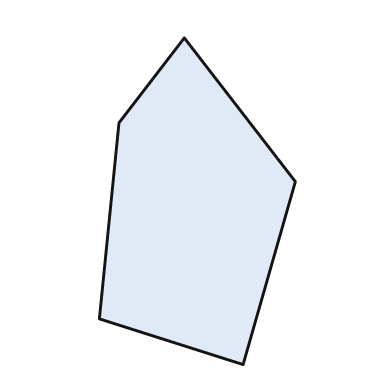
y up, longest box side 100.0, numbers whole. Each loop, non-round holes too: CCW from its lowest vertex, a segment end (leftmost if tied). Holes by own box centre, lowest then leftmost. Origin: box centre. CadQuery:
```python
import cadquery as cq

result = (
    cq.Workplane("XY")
    .moveTo(14.0, -50.0)
    .lineTo(30.0, 6.0)
    .lineTo(-4.0, 50.0)
    .lineTo(-24.0, 24.0)
    .lineTo(-30.0, -36.0)
    .close()
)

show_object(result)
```